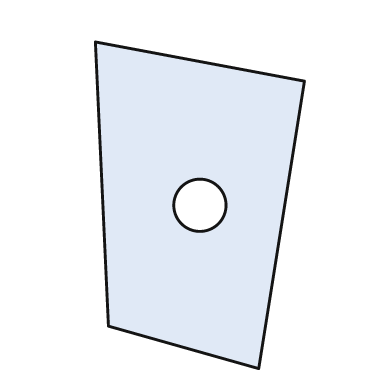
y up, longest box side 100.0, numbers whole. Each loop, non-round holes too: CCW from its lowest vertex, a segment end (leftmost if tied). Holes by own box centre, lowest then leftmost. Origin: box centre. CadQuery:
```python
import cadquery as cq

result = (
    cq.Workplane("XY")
    .moveTo(18.0, -50.0)
    .lineTo(32.0, 38.0)
    .lineTo(-32.0, 50.0)
    .lineTo(-28.0, -37.0)
    .close()
    .moveTo(0.0, 0.0)
    .circle(8.0)
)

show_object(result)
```